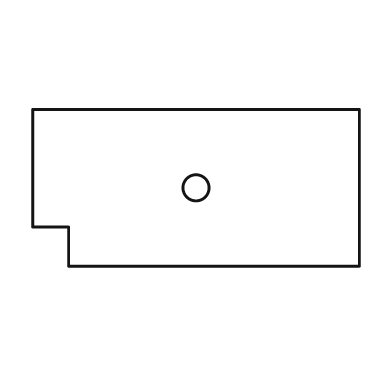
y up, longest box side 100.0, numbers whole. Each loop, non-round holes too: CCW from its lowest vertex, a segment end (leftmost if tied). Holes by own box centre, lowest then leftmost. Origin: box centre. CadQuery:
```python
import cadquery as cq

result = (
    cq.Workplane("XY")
    .moveTo(-39.0, -24.0)
    .lineTo(50.0, -24.0)
    .lineTo(50.0, 24.0)
    .lineTo(-50.0, 24.0)
    .lineTo(-50.0, -12.0)
    .lineTo(-39.0, -12.0)
    .close()
    .moveTo(0.0, 0.0)
    .circle(4.0)
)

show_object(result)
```